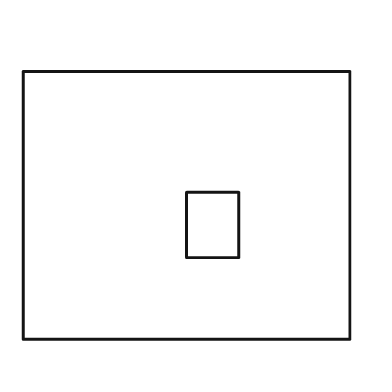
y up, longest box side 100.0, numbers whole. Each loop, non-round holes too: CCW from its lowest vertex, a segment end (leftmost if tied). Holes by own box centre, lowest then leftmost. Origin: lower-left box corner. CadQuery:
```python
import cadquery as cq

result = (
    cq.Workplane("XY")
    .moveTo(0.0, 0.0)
    .lineTo(100.0, 0.0)
    .lineTo(100.0, 82.0)
    .lineTo(0.0, 82.0)
    .close()
    .moveTo(50.0, 25.0)
    .lineTo(66.0, 25.0)
    .lineTo(66.0, 45.0)
    .lineTo(50.0, 45.0)
    .close()
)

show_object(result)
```